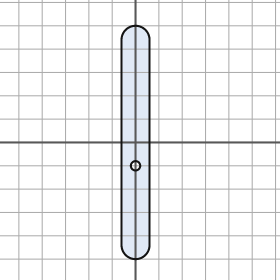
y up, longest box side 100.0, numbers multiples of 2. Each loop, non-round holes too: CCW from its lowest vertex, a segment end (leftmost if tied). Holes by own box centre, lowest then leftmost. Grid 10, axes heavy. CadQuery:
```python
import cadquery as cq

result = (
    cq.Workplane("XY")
    .moveTo(-6.0, -44.0)
    .threePointArc((0.0, -50.0), (6.0, -44.0))
    .lineTo(6.0, 44.0)
    .threePointArc((0.0, 50.0), (-6.0, 44.0))
    .close()
    .moveTo(0.0, -10.0)
    .circle(2.0)
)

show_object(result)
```